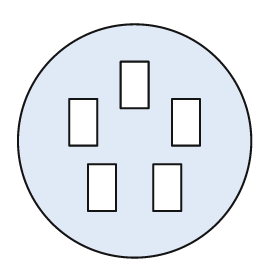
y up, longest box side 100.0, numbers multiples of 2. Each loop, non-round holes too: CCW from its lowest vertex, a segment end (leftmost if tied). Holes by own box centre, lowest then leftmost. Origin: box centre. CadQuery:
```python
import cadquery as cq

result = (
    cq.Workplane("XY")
    .moveTo(0.0, 0.0)
    .circle(50.0)
    .moveTo(-20.0, -30.0)
    .lineTo(-8.0, -30.0)
    .lineTo(-8.0, -10.0)
    .lineTo(-20.0, -10.0)
    .close()
    .moveTo(8.0, -30.0)
    .lineTo(20.0, -30.0)
    .lineTo(20.0, -10.0)
    .lineTo(8.0, -10.0)
    .close()
    .moveTo(-28.0, -2.0)
    .lineTo(-16.0, -2.0)
    .lineTo(-16.0, 18.0)
    .lineTo(-28.0, 18.0)
    .close()
    .moveTo(16.0, -2.0)
    .lineTo(28.0, -2.0)
    .lineTo(28.0, 18.0)
    .lineTo(16.0, 18.0)
    .close()
    .moveTo(-6.0, 14.0)
    .lineTo(6.0, 14.0)
    .lineTo(6.0, 34.0)
    .lineTo(-6.0, 34.0)
    .close()
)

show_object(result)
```